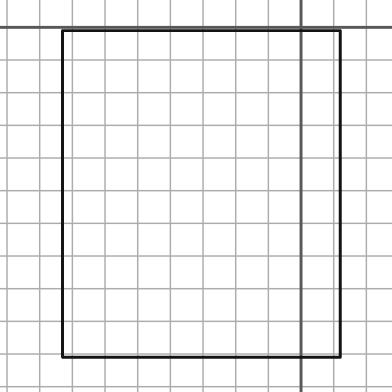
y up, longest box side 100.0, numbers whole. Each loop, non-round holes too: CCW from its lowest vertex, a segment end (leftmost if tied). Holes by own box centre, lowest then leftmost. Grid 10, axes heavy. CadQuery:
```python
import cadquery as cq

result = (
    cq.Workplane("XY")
    .moveTo(-73.0, -101.0)
    .lineTo(12.0, -101.0)
    .lineTo(12.0, -1.0)
    .lineTo(-73.0, -1.0)
    .close()
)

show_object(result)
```